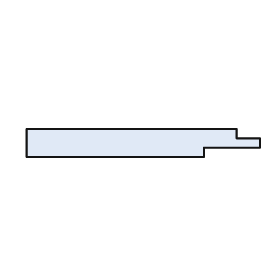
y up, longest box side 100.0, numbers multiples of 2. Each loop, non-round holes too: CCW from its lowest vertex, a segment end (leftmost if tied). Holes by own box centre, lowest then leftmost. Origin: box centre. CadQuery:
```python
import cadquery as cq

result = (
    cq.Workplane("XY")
    .moveTo(-50.0, -6.0)
    .lineTo(26.0, -6.0)
    .lineTo(26.0, -2.0)
    .lineTo(50.0, -2.0)
    .lineTo(50.0, 2.0)
    .lineTo(40.0, 2.0)
    .lineTo(40.0, 6.0)
    .lineTo(-50.0, 6.0)
    .close()
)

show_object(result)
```